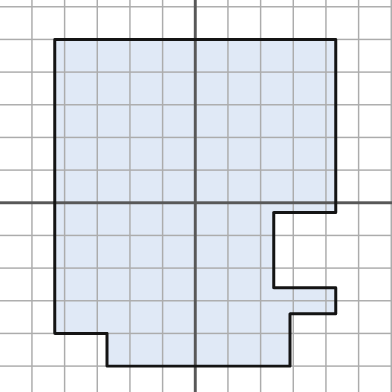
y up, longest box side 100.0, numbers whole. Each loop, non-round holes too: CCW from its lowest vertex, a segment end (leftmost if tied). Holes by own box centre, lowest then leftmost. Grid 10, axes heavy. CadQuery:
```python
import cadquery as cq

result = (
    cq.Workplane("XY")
    .moveTo(-27.0, -50.0)
    .lineTo(29.0, -50.0)
    .lineTo(29.0, -34.0)
    .lineTo(43.0, -34.0)
    .lineTo(43.0, -26.0)
    .lineTo(24.0, -26.0)
    .lineTo(24.0, -3.0)
    .lineTo(43.0, -3.0)
    .lineTo(43.0, 50.0)
    .lineTo(-43.0, 50.0)
    .lineTo(-43.0, -40.0)
    .lineTo(-27.0, -40.0)
    .close()
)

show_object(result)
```